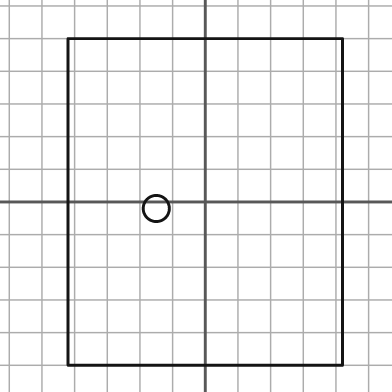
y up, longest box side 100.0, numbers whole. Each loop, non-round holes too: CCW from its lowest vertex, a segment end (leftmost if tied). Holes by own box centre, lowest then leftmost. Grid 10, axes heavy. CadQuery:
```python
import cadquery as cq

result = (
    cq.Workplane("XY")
    .moveTo(-42.0, -50.0)
    .lineTo(42.0, -50.0)
    .lineTo(42.0, 50.0)
    .lineTo(-42.0, 50.0)
    .close()
    .moveTo(-15.0, -2.0)
    .circle(4.0)
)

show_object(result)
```